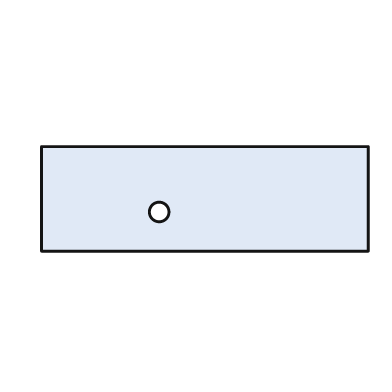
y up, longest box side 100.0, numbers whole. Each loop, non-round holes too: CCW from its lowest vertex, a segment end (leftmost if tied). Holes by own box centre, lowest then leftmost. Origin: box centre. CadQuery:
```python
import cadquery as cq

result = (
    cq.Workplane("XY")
    .moveTo(-50.0, -16.0)
    .lineTo(50.0, -16.0)
    .lineTo(50.0, 16.0)
    .lineTo(-50.0, 16.0)
    .close()
    .moveTo(-14.0, -4.0)
    .circle(3.0)
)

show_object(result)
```